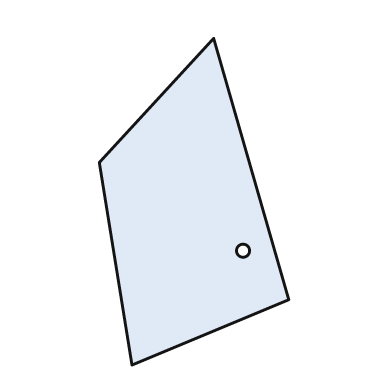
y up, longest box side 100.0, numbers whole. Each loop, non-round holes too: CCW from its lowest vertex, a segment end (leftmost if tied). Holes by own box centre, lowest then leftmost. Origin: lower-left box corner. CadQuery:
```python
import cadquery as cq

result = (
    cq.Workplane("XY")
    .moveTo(10.0, 0.0)
    .lineTo(58.0, 20.0)
    .lineTo(35.0, 100.0)
    .lineTo(0.0, 62.0)
    .close()
    .moveTo(44.0, 35.0)
    .circle(2.0)
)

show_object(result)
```